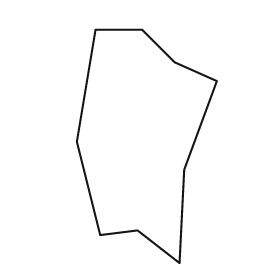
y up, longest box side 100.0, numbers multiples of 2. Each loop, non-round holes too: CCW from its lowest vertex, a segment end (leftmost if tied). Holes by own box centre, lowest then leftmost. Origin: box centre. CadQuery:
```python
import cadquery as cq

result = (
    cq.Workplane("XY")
    .moveTo(14.0, -50.0)
    .lineTo(16.0, -10.0)
    .lineTo(30.0, 28.0)
    .lineTo(12.0, 36.0)
    .lineTo(-2.0, 50.0)
    .lineTo(-22.0, 50.0)
    .lineTo(-30.0, 2.0)
    .lineTo(-20.0, -38.0)
    .lineTo(-4.0, -36.0)
    .close()
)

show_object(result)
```